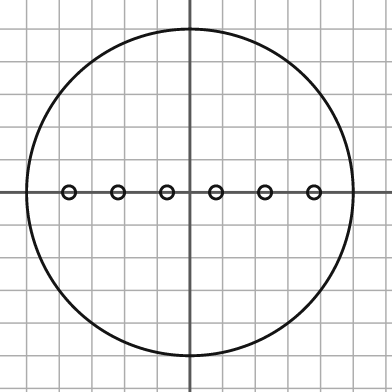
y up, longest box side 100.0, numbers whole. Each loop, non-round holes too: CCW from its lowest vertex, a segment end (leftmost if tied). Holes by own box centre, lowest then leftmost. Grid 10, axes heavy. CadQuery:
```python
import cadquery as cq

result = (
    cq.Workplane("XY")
    .moveTo(0.0, 0.0)
    .circle(50.0)
    .moveTo(-37.0, 0.0)
    .circle(2.0)
    .moveTo(-22.0, 0.0)
    .circle(2.0)
    .moveTo(-7.0, 0.0)
    .circle(2.0)
    .moveTo(8.0, 0.0)
    .circle(2.0)
    .moveTo(23.0, 0.0)
    .circle(2.0)
    .moveTo(38.0, 0.0)
    .circle(2.0)
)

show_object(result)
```